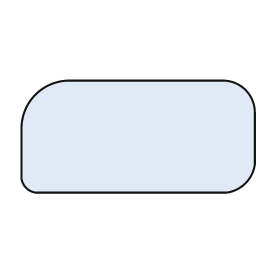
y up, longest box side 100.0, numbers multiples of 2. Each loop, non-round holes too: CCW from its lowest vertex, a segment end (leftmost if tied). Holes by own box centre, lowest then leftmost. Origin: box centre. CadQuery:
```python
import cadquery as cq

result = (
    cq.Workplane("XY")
    .moveTo(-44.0, -24.0)
    .lineTo(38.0, -24.0)
    .threePointArc((46.0, -20.0), (50.0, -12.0))
    .lineTo(50.0, 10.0)
    .threePointArc((46.0, 20.0), (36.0, 24.0))
    .lineTo(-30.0, 24.0)
    .threePointArc((-44.0, 18.0), (-50.0, 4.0))
    .lineTo(-50.0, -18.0)
    .threePointArc((-48.0, -22.0), (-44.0, -24.0))
    .close()
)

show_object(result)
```